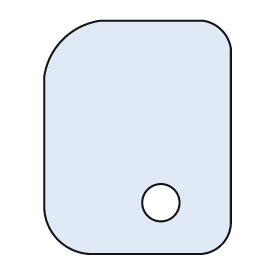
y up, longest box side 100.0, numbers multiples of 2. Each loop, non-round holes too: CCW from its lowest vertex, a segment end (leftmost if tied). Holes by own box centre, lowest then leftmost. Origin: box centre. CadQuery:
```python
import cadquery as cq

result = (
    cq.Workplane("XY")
    .moveTo(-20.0, -50.0)
    .lineTo(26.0, -50.0)
    .threePointArc((36.0, -46.0), (40.0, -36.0))
    .lineTo(40.0, 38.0)
    .threePointArc((36.0, 46.0), (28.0, 50.0))
    .lineTo(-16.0, 50.0)
    .threePointArc((-32.0, 42.0), (-40.0, 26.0))
    .lineTo(-40.0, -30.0)
    .threePointArc((-34.0, -44.0), (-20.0, -50.0))
    .close()
    .moveTo(10.0, -28.0)
    .circle(8.0)
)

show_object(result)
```